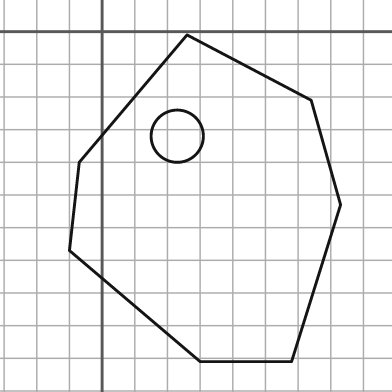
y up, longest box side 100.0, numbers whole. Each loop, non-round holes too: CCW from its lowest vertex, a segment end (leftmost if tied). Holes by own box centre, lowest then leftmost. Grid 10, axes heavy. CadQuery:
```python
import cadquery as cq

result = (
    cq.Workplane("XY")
    .moveTo(30.0, -101.0)
    .lineTo(58.0, -101.0)
    .lineTo(73.0, -53.0)
    .lineTo(64.0, -21.0)
    .lineTo(26.0, -1.0)
    .lineTo(-7.0, -40.0)
    .lineTo(-10.0, -67.0)
    .close()
    .moveTo(23.0, -32.0)
    .circle(8.0)
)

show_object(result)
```